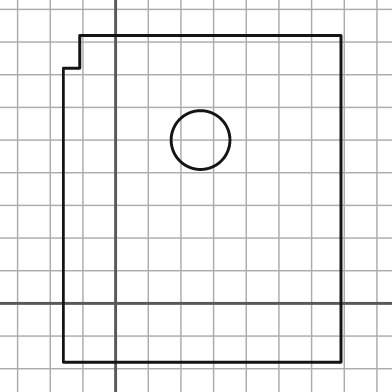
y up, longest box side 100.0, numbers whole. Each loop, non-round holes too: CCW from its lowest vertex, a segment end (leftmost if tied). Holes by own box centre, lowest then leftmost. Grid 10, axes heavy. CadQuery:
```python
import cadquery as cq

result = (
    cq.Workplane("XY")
    .moveTo(-16.0, -18.0)
    .lineTo(69.0, -18.0)
    .lineTo(69.0, 82.0)
    .lineTo(-11.0, 82.0)
    .lineTo(-11.0, 72.0)
    .lineTo(-16.0, 72.0)
    .close()
    .moveTo(26.0, 50.0)
    .circle(9.0)
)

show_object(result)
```